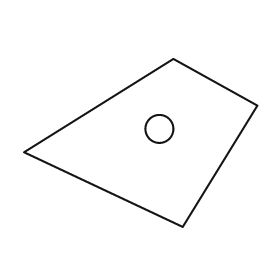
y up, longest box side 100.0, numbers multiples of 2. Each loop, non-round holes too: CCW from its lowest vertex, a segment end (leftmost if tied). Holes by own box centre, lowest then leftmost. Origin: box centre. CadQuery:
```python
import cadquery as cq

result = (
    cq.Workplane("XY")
    .moveTo(18.0, -36.0)
    .lineTo(50.0, 16.0)
    .lineTo(14.0, 36.0)
    .lineTo(-50.0, -4.0)
    .close()
    .moveTo(8.0, 6.0)
    .circle(6.0)
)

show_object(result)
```